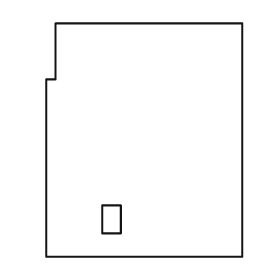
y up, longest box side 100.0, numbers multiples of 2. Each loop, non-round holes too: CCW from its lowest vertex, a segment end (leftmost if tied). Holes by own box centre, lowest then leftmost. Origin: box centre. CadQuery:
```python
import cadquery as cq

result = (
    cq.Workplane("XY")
    .moveTo(-42.0, -50.0)
    .lineTo(42.0, -50.0)
    .lineTo(42.0, 50.0)
    .lineTo(-38.0, 50.0)
    .lineTo(-38.0, 26.0)
    .lineTo(-42.0, 26.0)
    .close()
    .moveTo(-18.0, -40.0)
    .lineTo(-10.0, -40.0)
    .lineTo(-10.0, -28.0)
    .lineTo(-18.0, -28.0)
    .close()
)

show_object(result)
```